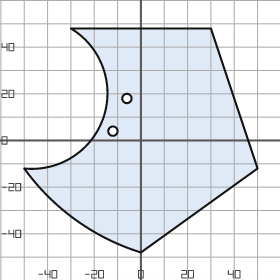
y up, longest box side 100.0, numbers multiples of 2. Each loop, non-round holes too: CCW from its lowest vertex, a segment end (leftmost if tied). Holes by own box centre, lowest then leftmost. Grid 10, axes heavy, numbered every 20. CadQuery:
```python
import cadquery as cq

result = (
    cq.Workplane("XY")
    .moveTo(0.0, -48.0)
    .lineTo(50.0, -12.0)
    .lineTo(30.0, 48.0)
    .lineTo(-30.0, 48.0)
    .threePointArc((-16.0, 10.0), (-50.0, -12.0))
    .threePointArc((-28.0, -34.0), (0.0, -48.0))
    .close()
    .moveTo(-12.0, 4.0)
    .circle(2.0)
    .moveTo(-6.0, 18.0)
    .circle(2.0)
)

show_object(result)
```